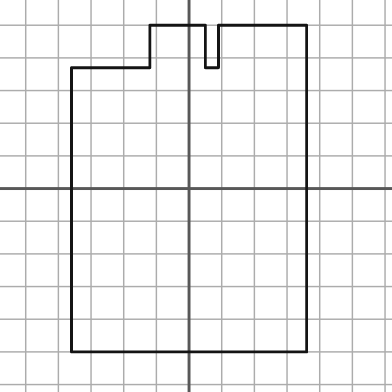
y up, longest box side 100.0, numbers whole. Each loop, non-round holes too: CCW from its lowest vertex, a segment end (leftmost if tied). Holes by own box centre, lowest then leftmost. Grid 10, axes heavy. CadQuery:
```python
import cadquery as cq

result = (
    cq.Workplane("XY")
    .moveTo(-36.0, -50.0)
    .lineTo(36.0, -50.0)
    .lineTo(36.0, 50.0)
    .lineTo(9.0, 50.0)
    .lineTo(9.0, 37.0)
    .lineTo(5.0, 37.0)
    .lineTo(5.0, 50.0)
    .lineTo(-12.0, 50.0)
    .lineTo(-12.0, 37.0)
    .lineTo(-36.0, 37.0)
    .close()
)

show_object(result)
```